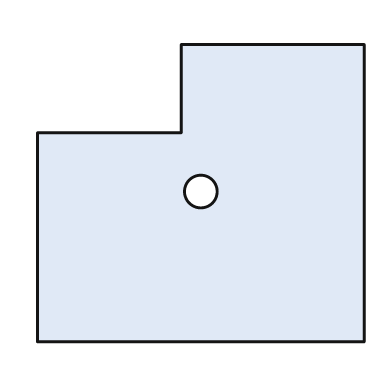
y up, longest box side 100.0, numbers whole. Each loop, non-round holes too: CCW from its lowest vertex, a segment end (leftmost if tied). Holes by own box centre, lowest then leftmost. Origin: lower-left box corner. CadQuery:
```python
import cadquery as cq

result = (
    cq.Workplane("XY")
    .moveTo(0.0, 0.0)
    .lineTo(100.0, 0.0)
    .lineTo(100.0, 91.0)
    .lineTo(44.0, 91.0)
    .lineTo(44.0, 64.0)
    .lineTo(0.0, 64.0)
    .close()
    .moveTo(50.0, 46.0)
    .circle(5.0)
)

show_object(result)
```